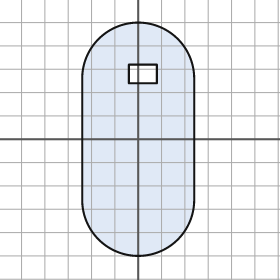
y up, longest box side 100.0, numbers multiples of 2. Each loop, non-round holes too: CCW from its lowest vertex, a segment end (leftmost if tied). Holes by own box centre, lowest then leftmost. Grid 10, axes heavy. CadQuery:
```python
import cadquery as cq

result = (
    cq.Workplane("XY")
    .moveTo(-24.0, -26.0)
    .threePointArc((0.0, -50.0), (24.0, -26.0))
    .lineTo(24.0, 26.0)
    .threePointArc((0.0, 50.0), (-24.0, 26.0))
    .close()
    .moveTo(-4.0, 24.0)
    .lineTo(8.0, 24.0)
    .lineTo(8.0, 32.0)
    .lineTo(-4.0, 32.0)
    .close()
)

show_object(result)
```